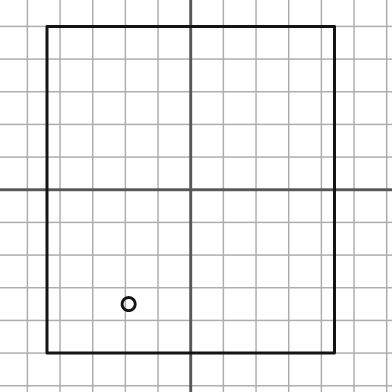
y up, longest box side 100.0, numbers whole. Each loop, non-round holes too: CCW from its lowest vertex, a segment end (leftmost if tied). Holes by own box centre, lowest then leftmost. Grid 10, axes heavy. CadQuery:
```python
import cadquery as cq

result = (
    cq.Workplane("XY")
    .moveTo(-44.0, -50.0)
    .lineTo(44.0, -50.0)
    .lineTo(44.0, 50.0)
    .lineTo(-44.0, 50.0)
    .close()
    .moveTo(-19.0, -35.0)
    .circle(2.0)
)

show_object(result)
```